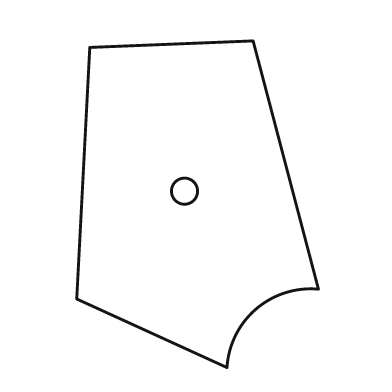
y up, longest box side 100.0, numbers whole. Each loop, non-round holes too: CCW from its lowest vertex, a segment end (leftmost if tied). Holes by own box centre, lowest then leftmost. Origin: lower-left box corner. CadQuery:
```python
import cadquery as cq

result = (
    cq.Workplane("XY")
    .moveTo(46.0, 0.0)
    .threePointArc((55.0, 18.0), (74.0, 24.0))
    .lineTo(54.0, 100.0)
    .lineTo(4.0, 98.0)
    .lineTo(0.0, 21.0)
    .close()
    .moveTo(33.0, 54.0)
    .circle(4.0)
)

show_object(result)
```